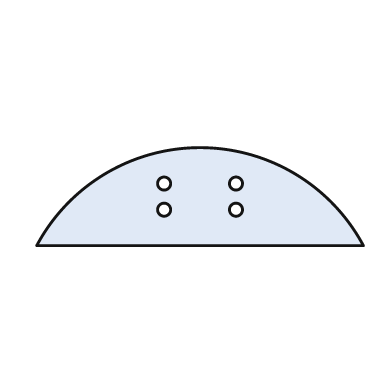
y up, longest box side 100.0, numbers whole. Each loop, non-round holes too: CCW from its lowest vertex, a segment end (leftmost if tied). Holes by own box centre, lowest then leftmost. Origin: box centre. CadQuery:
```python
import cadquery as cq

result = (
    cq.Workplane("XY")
    .moveTo(-50.0, -15.0)
    .lineTo(50.0, -15.0)
    .threePointArc((0.0, 15.0), (-50.0, -15.0))
    .close()
    .moveTo(-11.0, -4.0)
    .circle(2.0)
    .moveTo(11.0, -4.0)
    .circle(2.0)
    .moveTo(-11.0, 4.0)
    .circle(2.0)
    .moveTo(11.0, 4.0)
    .circle(2.0)
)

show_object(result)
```